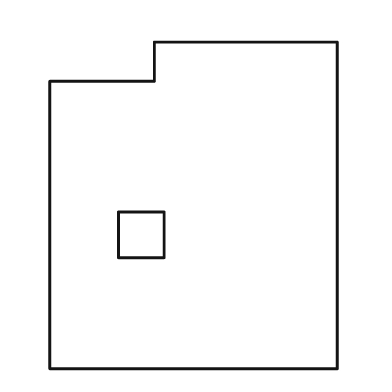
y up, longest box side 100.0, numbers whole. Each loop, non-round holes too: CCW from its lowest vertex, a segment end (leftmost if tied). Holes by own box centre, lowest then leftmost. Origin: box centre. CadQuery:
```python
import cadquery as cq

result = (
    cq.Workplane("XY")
    .moveTo(-44.0, -50.0)
    .lineTo(44.0, -50.0)
    .lineTo(44.0, 50.0)
    .lineTo(-12.0, 50.0)
    .lineTo(-12.0, 38.0)
    .lineTo(-44.0, 38.0)
    .close()
    .moveTo(-23.0, -16.0)
    .lineTo(-9.0, -16.0)
    .lineTo(-9.0, -2.0)
    .lineTo(-23.0, -2.0)
    .close()
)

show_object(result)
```